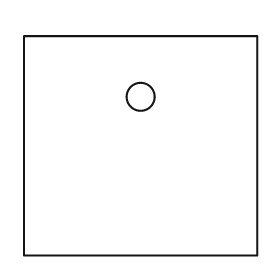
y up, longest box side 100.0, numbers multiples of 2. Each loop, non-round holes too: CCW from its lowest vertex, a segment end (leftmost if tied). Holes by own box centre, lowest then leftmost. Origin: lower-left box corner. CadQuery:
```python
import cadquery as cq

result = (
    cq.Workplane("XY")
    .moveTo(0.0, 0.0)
    .lineTo(100.0, 0.0)
    .lineTo(100.0, 94.0)
    .lineTo(0.0, 94.0)
    .close()
    .moveTo(50.0, 68.0)
    .circle(6.0)
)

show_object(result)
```